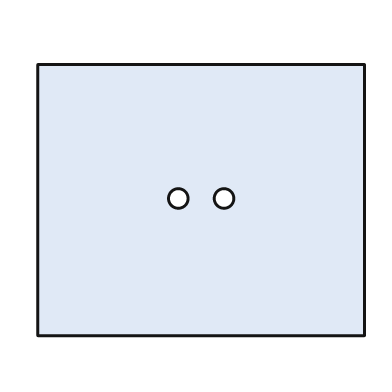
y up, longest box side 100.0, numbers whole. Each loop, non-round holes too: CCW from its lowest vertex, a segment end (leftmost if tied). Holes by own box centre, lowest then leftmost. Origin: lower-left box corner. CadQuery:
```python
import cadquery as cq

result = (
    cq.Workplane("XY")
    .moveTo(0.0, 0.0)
    .lineTo(100.0, 0.0)
    .lineTo(100.0, 83.0)
    .lineTo(0.0, 83.0)
    .close()
    .moveTo(43.0, 42.0)
    .circle(3.0)
    .moveTo(57.0, 42.0)
    .circle(3.0)
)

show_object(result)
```